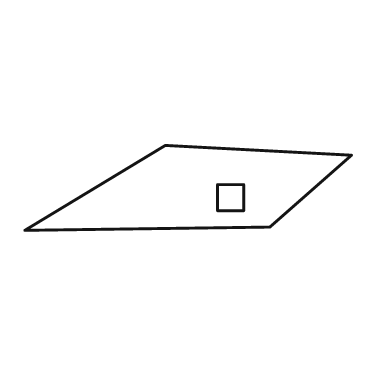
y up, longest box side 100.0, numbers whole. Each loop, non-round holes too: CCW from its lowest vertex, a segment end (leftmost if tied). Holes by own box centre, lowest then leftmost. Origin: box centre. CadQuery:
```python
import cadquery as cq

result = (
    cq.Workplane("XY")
    .moveTo(-50.0, -13.0)
    .lineTo(25.0, -12.0)
    .lineTo(50.0, 10.0)
    .lineTo(-7.0, 13.0)
    .close()
    .moveTo(9.0, -7.0)
    .lineTo(17.0, -7.0)
    .lineTo(17.0, 1.0)
    .lineTo(9.0, 1.0)
    .close()
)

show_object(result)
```